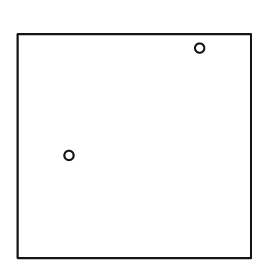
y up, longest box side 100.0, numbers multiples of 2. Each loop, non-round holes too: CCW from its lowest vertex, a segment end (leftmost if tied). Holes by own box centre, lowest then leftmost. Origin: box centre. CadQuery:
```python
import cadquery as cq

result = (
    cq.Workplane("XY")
    .moveTo(-50.0, -48.0)
    .lineTo(50.0, -48.0)
    .lineTo(50.0, 48.0)
    .lineTo(-50.0, 48.0)
    .close()
    .moveTo(-28.0, -4.0)
    .circle(2.0)
    .moveTo(28.0, 42.0)
    .circle(2.0)
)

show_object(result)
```